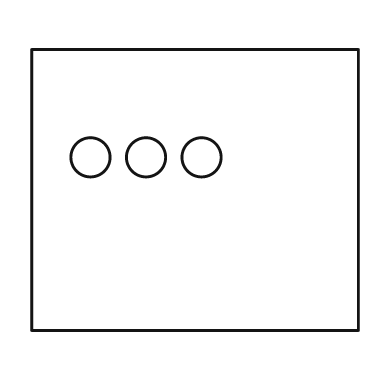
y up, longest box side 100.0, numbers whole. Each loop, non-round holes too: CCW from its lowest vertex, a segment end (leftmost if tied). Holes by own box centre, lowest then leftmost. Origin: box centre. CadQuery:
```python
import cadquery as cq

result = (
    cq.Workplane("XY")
    .moveTo(-50.0, -43.0)
    .lineTo(50.0, -43.0)
    .lineTo(50.0, 43.0)
    .lineTo(-50.0, 43.0)
    .close()
    .moveTo(-32.0, 10.0)
    .circle(6.0)
    .moveTo(-15.0, 10.0)
    .circle(6.0)
    .moveTo(2.0, 10.0)
    .circle(6.0)
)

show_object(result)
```